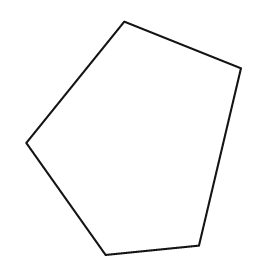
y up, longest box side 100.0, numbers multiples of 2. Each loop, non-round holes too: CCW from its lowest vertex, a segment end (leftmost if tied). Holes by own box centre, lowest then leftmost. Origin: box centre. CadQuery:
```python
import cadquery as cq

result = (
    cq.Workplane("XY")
    .moveTo(-12.0, -50.0)
    .lineTo(28.0, -46.0)
    .lineTo(46.0, 30.0)
    .lineTo(-4.0, 50.0)
    .lineTo(-46.0, -2.0)
    .close()
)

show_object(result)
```